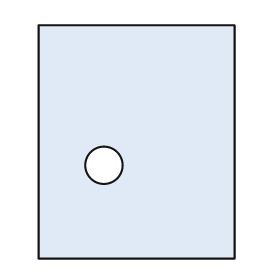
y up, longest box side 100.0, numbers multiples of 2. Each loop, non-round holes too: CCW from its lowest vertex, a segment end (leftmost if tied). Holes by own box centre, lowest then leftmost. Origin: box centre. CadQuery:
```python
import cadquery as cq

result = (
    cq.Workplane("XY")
    .moveTo(-42.0, -50.0)
    .lineTo(42.0, -50.0)
    .lineTo(42.0, 50.0)
    .lineTo(-42.0, 50.0)
    .close()
    .moveTo(-14.0, -10.0)
    .circle(8.0)
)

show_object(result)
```